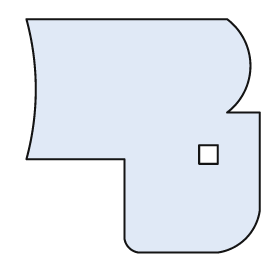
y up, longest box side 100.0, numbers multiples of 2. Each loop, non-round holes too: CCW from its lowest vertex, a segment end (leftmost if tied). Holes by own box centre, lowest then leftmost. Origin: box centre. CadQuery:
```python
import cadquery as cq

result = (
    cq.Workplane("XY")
    .moveTo(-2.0, -50.0)
    .lineTo(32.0, -50.0)
    .threePointArc((44.0, -44.0), (50.0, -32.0))
    .lineTo(50.0, 10.0)
    .lineTo(36.0, 10.0)
    .threePointArc((46.0, 30.0), (36.0, 50.0))
    .lineTo(-50.0, 50.0)
    .threePointArc((-46.0, 20.0), (-50.0, -10.0))
    .lineTo(-8.0, -10.0)
    .lineTo(-8.0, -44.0)
    .threePointArc((-6.0, -48.0), (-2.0, -50.0))
    .close()
    .moveTo(24.0, -12.0)
    .lineTo(32.0, -12.0)
    .lineTo(32.0, -4.0)
    .lineTo(24.0, -4.0)
    .close()
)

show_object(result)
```